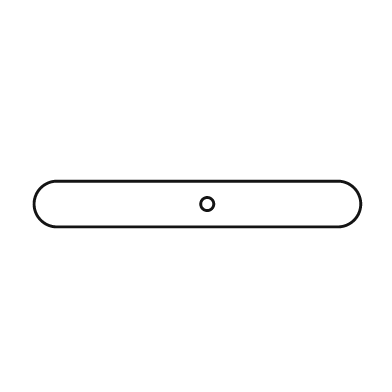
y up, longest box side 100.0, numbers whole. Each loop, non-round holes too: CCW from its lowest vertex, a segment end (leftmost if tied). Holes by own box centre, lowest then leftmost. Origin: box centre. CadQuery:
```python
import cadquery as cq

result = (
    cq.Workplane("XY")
    .moveTo(-43.0, -7.0)
    .lineTo(43.0, -7.0)
    .threePointArc((50.0, 0.0), (43.0, 7.0))
    .lineTo(-43.0, 7.0)
    .threePointArc((-50.0, 0.0), (-43.0, -7.0))
    .close()
    .moveTo(3.0, 0.0)
    .circle(2.0)
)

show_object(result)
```